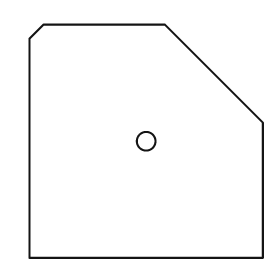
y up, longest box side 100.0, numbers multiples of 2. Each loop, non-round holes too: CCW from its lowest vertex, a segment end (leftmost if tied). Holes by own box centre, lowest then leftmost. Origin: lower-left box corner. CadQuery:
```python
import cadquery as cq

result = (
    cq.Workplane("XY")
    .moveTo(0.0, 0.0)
    .lineTo(100.0, 0.0)
    .lineTo(100.0, 58.0)
    .lineTo(58.0, 100.0)
    .lineTo(6.0, 100.0)
    .lineTo(0.0, 94.0)
    .close()
    .moveTo(50.0, 50.0)
    .circle(4.0)
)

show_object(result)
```